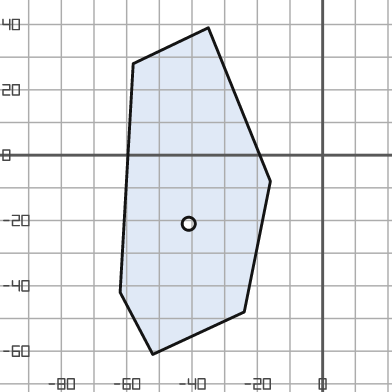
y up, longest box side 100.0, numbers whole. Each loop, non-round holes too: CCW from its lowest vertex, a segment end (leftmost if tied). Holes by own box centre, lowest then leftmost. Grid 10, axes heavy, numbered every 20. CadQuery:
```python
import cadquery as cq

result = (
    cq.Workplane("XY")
    .moveTo(-52.0, -61.0)
    .lineTo(-24.0, -48.0)
    .lineTo(-16.0, -8.0)
    .lineTo(-35.0, 39.0)
    .lineTo(-58.0, 28.0)
    .lineTo(-62.0, -42.0)
    .close()
    .moveTo(-41.0, -21.0)
    .circle(2.0)
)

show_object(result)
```